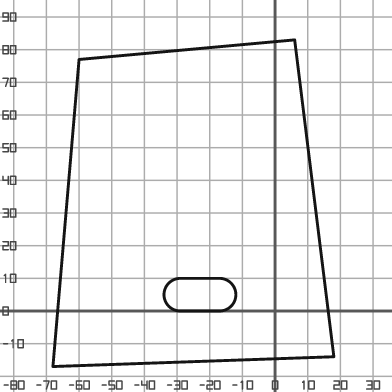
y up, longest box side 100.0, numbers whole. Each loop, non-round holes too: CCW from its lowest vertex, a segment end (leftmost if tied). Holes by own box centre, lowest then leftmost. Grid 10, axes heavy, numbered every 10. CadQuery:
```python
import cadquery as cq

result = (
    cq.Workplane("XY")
    .moveTo(-68.0, -17.0)
    .lineTo(18.0, -14.0)
    .lineTo(6.0, 83.0)
    .lineTo(-60.0, 77.0)
    .close()
    .moveTo(-29.0, 0.0)
    .lineTo(-17.0, 0.0)
    .threePointArc((-12.0, 5.0), (-17.0, 10.0))
    .lineTo(-29.0, 10.0)
    .threePointArc((-34.0, 5.0), (-29.0, 0.0))
    .close()
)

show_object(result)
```